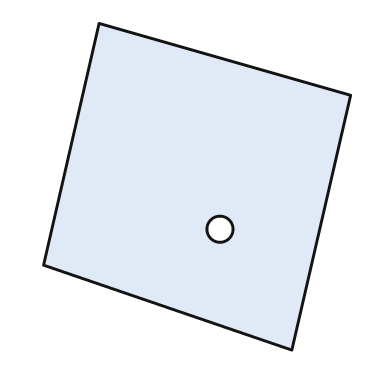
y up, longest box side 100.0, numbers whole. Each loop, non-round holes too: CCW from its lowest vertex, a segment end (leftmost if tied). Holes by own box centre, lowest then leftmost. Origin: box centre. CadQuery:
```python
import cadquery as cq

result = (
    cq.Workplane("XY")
    .moveTo(29.0, -50.0)
    .lineTo(47.0, 28.0)
    .lineTo(-30.0, 50.0)
    .lineTo(-47.0, -24.0)
    .close()
    .moveTo(7.0, -13.0)
    .circle(4.0)
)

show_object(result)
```